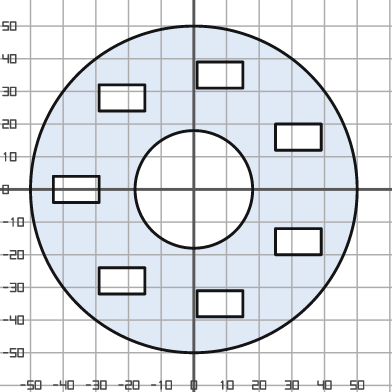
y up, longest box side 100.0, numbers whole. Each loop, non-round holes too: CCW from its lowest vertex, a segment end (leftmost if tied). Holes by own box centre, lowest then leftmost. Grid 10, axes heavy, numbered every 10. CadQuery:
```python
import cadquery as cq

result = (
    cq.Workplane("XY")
    .moveTo(0.0, 0.0)
    .circle(50.0)
    .moveTo(1.0, -39.0)
    .lineTo(15.0, -39.0)
    .lineTo(15.0, -31.0)
    .lineTo(1.0, -31.0)
    .close()
    .moveTo(-29.0, -32.0)
    .lineTo(-15.0, -32.0)
    .lineTo(-15.0, -24.0)
    .lineTo(-29.0, -24.0)
    .close()
    .moveTo(25.0, -20.0)
    .lineTo(39.0, -20.0)
    .lineTo(39.0, -12.0)
    .lineTo(25.0, -12.0)
    .close()
    .moveTo(-43.0, -4.0)
    .lineTo(-29.0, -4.0)
    .lineTo(-29.0, 4.0)
    .lineTo(-43.0, 4.0)
    .close()
    .moveTo(0.0, 0.0)
    .circle(18.0)
    .moveTo(25.0, 12.0)
    .lineTo(39.0, 12.0)
    .lineTo(39.0, 20.0)
    .lineTo(25.0, 20.0)
    .close()
    .moveTo(-29.0, 24.0)
    .lineTo(-15.0, 24.0)
    .lineTo(-15.0, 32.0)
    .lineTo(-29.0, 32.0)
    .close()
    .moveTo(1.0, 31.0)
    .lineTo(15.0, 31.0)
    .lineTo(15.0, 39.0)
    .lineTo(1.0, 39.0)
    .close()
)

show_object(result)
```